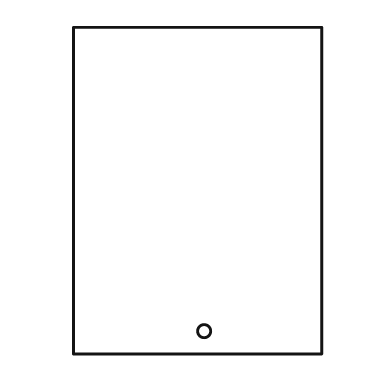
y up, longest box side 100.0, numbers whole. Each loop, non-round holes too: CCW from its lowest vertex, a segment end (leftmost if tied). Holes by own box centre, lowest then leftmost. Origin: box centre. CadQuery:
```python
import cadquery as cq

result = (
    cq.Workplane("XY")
    .moveTo(-38.0, -50.0)
    .lineTo(38.0, -50.0)
    .lineTo(38.0, 50.0)
    .lineTo(-38.0, 50.0)
    .close()
    .moveTo(2.0, -43.0)
    .circle(2.0)
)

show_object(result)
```